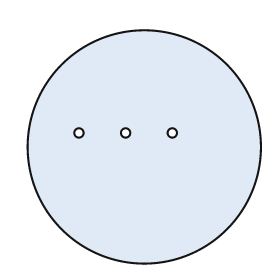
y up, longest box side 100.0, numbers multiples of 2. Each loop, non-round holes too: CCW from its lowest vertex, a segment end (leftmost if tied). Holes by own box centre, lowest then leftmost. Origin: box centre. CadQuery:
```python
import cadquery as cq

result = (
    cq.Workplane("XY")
    .moveTo(0.0, 0.0)
    .circle(50.0)
    .moveTo(-28.0, 6.0)
    .circle(2.0)
    .moveTo(-8.0, 6.0)
    .circle(2.0)
    .moveTo(12.0, 6.0)
    .circle(2.0)
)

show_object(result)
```